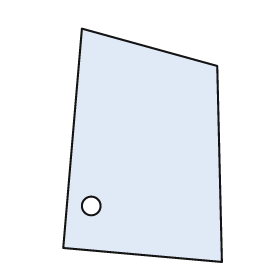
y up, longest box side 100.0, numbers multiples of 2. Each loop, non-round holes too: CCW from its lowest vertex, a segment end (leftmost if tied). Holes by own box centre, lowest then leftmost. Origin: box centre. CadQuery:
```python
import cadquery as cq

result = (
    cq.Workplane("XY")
    .moveTo(34.0, -50.0)
    .lineTo(32.0, 34.0)
    .lineTo(-26.0, 50.0)
    .lineTo(-34.0, -44.0)
    .close()
    .moveTo(-22.0, -26.0)
    .circle(4.0)
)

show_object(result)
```